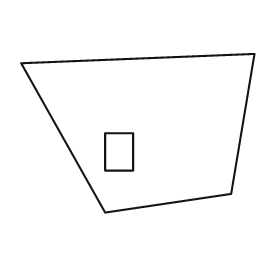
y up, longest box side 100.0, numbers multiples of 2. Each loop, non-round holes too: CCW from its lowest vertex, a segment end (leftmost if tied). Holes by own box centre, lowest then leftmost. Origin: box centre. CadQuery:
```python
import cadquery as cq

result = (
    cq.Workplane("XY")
    .moveTo(-14.0, -34.0)
    .lineTo(40.0, -26.0)
    .lineTo(50.0, 34.0)
    .lineTo(-50.0, 30.0)
    .close()
    .moveTo(-14.0, -16.0)
    .lineTo(-2.0, -16.0)
    .lineTo(-2.0, 0.0)
    .lineTo(-14.0, 0.0)
    .close()
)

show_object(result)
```